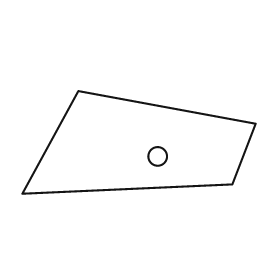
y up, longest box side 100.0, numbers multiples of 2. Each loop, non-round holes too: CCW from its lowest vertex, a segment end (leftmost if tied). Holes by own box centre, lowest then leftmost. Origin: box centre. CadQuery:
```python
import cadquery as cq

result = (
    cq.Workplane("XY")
    .moveTo(-50.0, -22.0)
    .lineTo(40.0, -18.0)
    .lineTo(50.0, 8.0)
    .lineTo(-26.0, 22.0)
    .close()
    .moveTo(8.0, -6.0)
    .circle(4.0)
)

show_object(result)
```